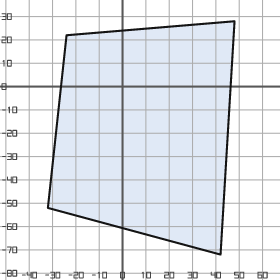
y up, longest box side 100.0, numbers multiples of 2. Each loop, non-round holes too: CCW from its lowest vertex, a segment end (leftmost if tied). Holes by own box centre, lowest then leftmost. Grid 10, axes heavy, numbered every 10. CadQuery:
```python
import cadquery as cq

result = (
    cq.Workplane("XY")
    .moveTo(42.0, -72.0)
    .lineTo(48.0, 28.0)
    .lineTo(-24.0, 22.0)
    .lineTo(-32.0, -52.0)
    .close()
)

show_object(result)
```